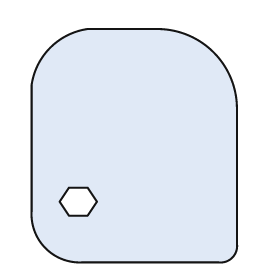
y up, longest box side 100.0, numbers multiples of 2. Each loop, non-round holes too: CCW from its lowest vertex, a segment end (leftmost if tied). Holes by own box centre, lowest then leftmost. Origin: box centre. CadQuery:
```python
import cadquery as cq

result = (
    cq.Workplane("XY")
    .moveTo(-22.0, -50.0)
    .lineTo(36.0, -50.0)
    .threePointArc((42.0, -48.0), (44.0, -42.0))
    .lineTo(44.0, 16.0)
    .threePointArc((34.0, 40.0), (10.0, 50.0))
    .lineTo(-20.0, 50.0)
    .threePointArc((-36.0, 42.0), (-44.0, 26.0))
    .lineTo(-44.0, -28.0)
    .threePointArc((-38.0, -44.0), (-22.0, -50.0))
    .close()
    .moveTo(-28.0, -30.0)
    .lineTo(-20.0, -30.0)
    .lineTo(-16.0, -24.0)
    .lineTo(-20.0, -18.0)
    .lineTo(-28.0, -18.0)
    .lineTo(-32.0, -24.0)
    .close()
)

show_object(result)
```